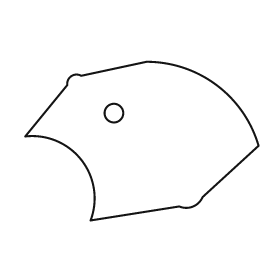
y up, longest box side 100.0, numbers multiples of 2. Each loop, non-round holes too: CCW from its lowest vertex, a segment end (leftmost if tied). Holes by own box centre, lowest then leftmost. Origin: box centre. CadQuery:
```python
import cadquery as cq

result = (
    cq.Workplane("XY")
    .moveTo(-22.0, -34.0)
    .lineTo(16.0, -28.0)
    .threePointArc((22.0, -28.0), (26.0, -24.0))
    .lineTo(50.0, -2.0)
    .threePointArc((32.0, 24.0), (2.0, 34.0))
    .lineTo(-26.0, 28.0)
    .threePointArc((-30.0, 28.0), (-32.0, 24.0))
    .lineTo(-50.0, 2.0)
    .threePointArc((-26.0, -8.0), (-22.0, -34.0))
    .close()
    .moveTo(-12.0, 12.0)
    .circle(4.0)
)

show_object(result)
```